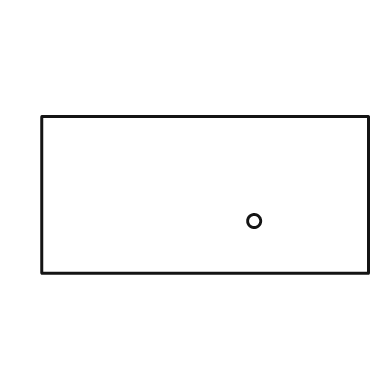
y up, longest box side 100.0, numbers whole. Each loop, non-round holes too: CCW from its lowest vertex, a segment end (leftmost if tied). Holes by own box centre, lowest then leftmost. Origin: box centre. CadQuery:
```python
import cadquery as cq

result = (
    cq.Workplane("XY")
    .moveTo(-50.0, -24.0)
    .lineTo(50.0, -24.0)
    .lineTo(50.0, 24.0)
    .lineTo(-50.0, 24.0)
    .close()
    .moveTo(15.0, -8.0)
    .circle(2.0)
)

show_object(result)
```